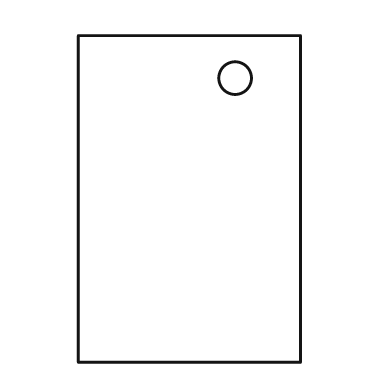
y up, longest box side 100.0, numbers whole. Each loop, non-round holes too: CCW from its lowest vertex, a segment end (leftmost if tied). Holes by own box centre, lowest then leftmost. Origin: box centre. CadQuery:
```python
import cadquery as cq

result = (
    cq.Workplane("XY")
    .moveTo(-34.0, -50.0)
    .lineTo(34.0, -50.0)
    .lineTo(34.0, 50.0)
    .lineTo(-34.0, 50.0)
    .close()
    .moveTo(14.0, 37.0)
    .circle(5.0)
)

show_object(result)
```